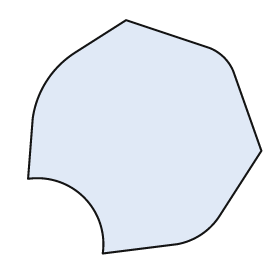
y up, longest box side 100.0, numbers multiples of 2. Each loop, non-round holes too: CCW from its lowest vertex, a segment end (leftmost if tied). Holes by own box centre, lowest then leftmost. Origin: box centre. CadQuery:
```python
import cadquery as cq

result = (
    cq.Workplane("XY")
    .moveTo(-18.0, -50.0)
    .lineTo(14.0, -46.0)
    .threePointArc((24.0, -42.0), (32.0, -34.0))
    .lineTo(50.0, -6.0)
    .lineTo(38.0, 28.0)
    .threePointArc((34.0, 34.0), (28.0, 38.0))
    .lineTo(-8.0, 50.0)
    .lineTo(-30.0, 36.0)
    .threePointArc((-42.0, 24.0), (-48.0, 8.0))
    .lineTo(-50.0, -18.0)
    .threePointArc((-26.0, -26.0), (-18.0, -50.0))
    .close()
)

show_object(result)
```